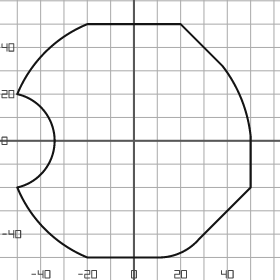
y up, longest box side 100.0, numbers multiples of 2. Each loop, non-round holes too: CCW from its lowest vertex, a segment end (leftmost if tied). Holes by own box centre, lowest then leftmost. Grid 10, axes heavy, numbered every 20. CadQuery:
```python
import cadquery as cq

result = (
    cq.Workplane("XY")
    .moveTo(-20.0, -50.0)
    .lineTo(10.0, -50.0)
    .threePointArc((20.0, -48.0), (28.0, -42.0))
    .lineTo(50.0, -20.0)
    .lineTo(50.0, 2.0)
    .threePointArc((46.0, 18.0), (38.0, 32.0))
    .lineTo(20.0, 50.0)
    .lineTo(-20.0, 50.0)
    .threePointArc((-38.0, 38.0), (-50.0, 20.0))
    .threePointArc((-34.0, 0.0), (-50.0, -20.0))
    .threePointArc((-38.0, -38.0), (-20.0, -50.0))
    .close()
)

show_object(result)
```